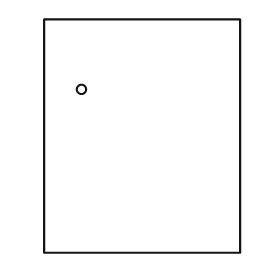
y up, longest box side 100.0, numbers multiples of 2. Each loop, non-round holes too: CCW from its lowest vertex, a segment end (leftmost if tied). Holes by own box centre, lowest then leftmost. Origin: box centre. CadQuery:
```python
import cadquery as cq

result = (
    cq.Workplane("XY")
    .moveTo(-42.0, -50.0)
    .lineTo(42.0, -50.0)
    .lineTo(42.0, 50.0)
    .lineTo(-42.0, 50.0)
    .close()
    .moveTo(-26.0, 20.0)
    .circle(2.0)
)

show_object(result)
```